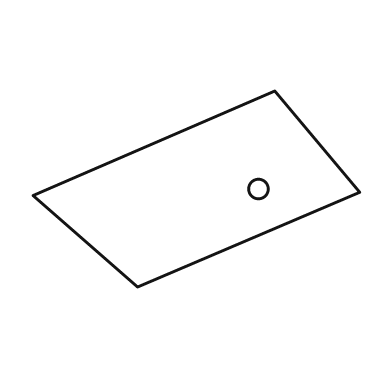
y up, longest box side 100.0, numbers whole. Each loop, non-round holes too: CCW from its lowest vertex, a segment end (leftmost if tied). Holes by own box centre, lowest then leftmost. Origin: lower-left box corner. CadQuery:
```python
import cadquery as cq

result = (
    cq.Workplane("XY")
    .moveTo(32.0, 0.0)
    .lineTo(100.0, 29.0)
    .lineTo(74.0, 60.0)
    .lineTo(0.0, 28.0)
    .close()
    .moveTo(69.0, 30.0)
    .circle(3.0)
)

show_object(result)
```